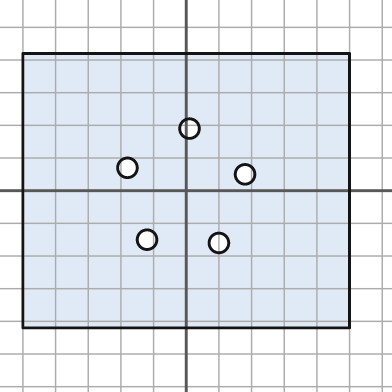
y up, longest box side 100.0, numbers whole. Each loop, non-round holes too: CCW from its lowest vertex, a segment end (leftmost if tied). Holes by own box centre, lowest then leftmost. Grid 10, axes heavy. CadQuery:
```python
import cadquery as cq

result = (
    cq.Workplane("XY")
    .moveTo(-50.0, -42.0)
    .lineTo(50.0, -42.0)
    .lineTo(50.0, 42.0)
    .lineTo(-50.0, 42.0)
    .close()
    .moveTo(10.0, -16.0)
    .circle(3.0)
    .moveTo(-12.0, -15.0)
    .circle(3.0)
    .moveTo(18.0, 5.0)
    .circle(3.0)
    .moveTo(-18.0, 7.0)
    .circle(3.0)
    .moveTo(1.0, 19.0)
    .circle(3.0)
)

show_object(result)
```